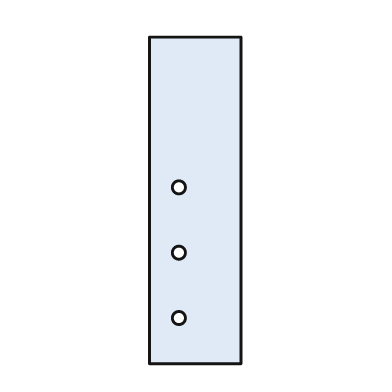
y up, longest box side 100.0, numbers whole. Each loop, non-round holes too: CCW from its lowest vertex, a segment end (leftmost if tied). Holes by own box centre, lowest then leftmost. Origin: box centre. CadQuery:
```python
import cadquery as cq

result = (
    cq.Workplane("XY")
    .moveTo(-14.0, -50.0)
    .lineTo(14.0, -50.0)
    .lineTo(14.0, 50.0)
    .lineTo(-14.0, 50.0)
    .close()
    .moveTo(-5.0, -36.0)
    .circle(2.0)
    .moveTo(-5.0, -16.0)
    .circle(2.0)
    .moveTo(-5.0, 4.0)
    .circle(2.0)
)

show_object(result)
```